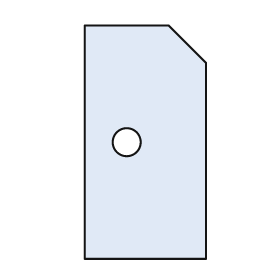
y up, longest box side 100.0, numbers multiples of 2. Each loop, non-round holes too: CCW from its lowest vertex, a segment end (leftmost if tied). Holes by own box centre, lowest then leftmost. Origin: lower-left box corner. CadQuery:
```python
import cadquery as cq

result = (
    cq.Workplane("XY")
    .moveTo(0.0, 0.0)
    .lineTo(52.0, 0.0)
    .lineTo(52.0, 84.0)
    .lineTo(36.0, 100.0)
    .lineTo(0.0, 100.0)
    .close()
    .moveTo(18.0, 50.0)
    .circle(6.0)
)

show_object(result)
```